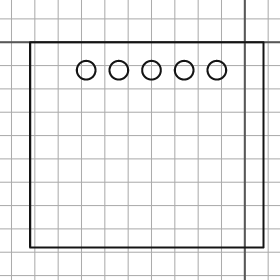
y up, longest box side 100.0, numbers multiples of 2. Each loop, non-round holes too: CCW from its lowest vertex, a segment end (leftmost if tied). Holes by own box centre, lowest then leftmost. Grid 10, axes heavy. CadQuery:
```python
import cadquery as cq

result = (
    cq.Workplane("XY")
    .moveTo(-92.0, -88.0)
    .lineTo(8.0, -88.0)
    .lineTo(8.0, 0.0)
    .lineTo(-92.0, 0.0)
    .close()
    .moveTo(-68.0, -12.0)
    .circle(4.0)
    .moveTo(-54.0, -12.0)
    .circle(4.0)
    .moveTo(-40.0, -12.0)
    .circle(4.0)
    .moveTo(-26.0, -12.0)
    .circle(4.0)
    .moveTo(-12.0, -12.0)
    .circle(4.0)
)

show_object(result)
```